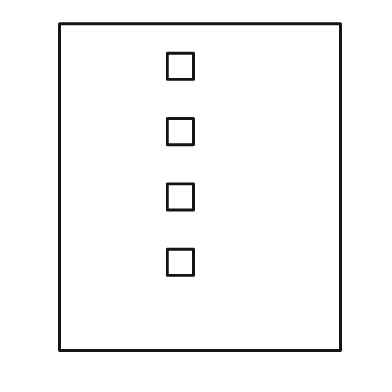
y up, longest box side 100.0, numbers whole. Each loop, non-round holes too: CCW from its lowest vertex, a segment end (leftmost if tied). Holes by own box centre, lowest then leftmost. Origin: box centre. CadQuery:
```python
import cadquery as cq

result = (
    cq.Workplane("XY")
    .moveTo(-43.0, -50.0)
    .lineTo(43.0, -50.0)
    .lineTo(43.0, 50.0)
    .lineTo(-43.0, 50.0)
    .close()
    .moveTo(-10.0, -27.0)
    .lineTo(-2.0, -27.0)
    .lineTo(-2.0, -19.0)
    .lineTo(-10.0, -19.0)
    .close()
    .moveTo(-10.0, -7.0)
    .lineTo(-2.0, -7.0)
    .lineTo(-2.0, 1.0)
    .lineTo(-10.0, 1.0)
    .close()
    .moveTo(-10.0, 13.0)
    .lineTo(-2.0, 13.0)
    .lineTo(-2.0, 21.0)
    .lineTo(-10.0, 21.0)
    .close()
    .moveTo(-10.0, 33.0)
    .lineTo(-2.0, 33.0)
    .lineTo(-2.0, 41.0)
    .lineTo(-10.0, 41.0)
    .close()
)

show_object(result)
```